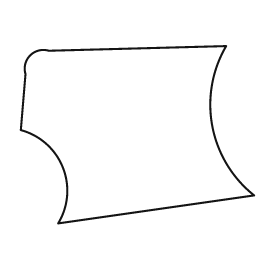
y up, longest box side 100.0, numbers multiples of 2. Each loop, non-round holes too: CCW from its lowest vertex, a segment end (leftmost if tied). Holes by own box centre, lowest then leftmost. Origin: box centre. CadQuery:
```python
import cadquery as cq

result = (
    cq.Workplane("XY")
    .moveTo(-34.0, -38.0)
    .lineTo(50.0, -26.0)
    .threePointArc((32.0, 4.0), (38.0, 38.0))
    .lineTo(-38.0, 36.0)
    .threePointArc((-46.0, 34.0), (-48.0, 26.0))
    .lineTo(-50.0, 2.0)
    .threePointArc((-32.0, -14.0), (-34.0, -38.0))
    .close()
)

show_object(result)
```